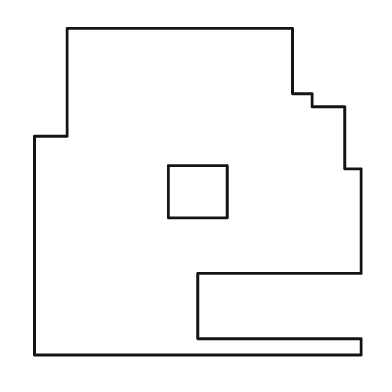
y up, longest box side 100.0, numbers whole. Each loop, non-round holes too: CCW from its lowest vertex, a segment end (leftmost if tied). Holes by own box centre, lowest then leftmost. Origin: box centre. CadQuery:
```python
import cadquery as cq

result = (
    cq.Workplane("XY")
    .moveTo(-50.0, -50.0)
    .lineTo(50.0, -50.0)
    .lineTo(50.0, -45.0)
    .lineTo(0.0, -45.0)
    .lineTo(0.0, -25.0)
    .lineTo(50.0, -25.0)
    .lineTo(50.0, 7.0)
    .lineTo(45.0, 7.0)
    .lineTo(45.0, 26.0)
    .lineTo(35.0, 26.0)
    .lineTo(35.0, 30.0)
    .lineTo(29.0, 30.0)
    .lineTo(29.0, 50.0)
    .lineTo(-40.0, 50.0)
    .lineTo(-40.0, 17.0)
    .lineTo(-50.0, 17.0)
    .close()
    .moveTo(-9.0, -8.0)
    .lineTo(9.0, -8.0)
    .lineTo(9.0, 8.0)
    .lineTo(-9.0, 8.0)
    .close()
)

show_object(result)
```